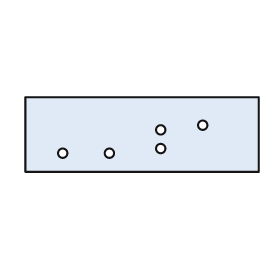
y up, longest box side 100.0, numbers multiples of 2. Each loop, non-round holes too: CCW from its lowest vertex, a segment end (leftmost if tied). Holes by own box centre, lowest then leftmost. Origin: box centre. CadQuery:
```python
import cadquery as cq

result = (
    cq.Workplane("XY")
    .moveTo(-50.0, -16.0)
    .lineTo(50.0, -16.0)
    .lineTo(50.0, 16.0)
    .lineTo(-50.0, 16.0)
    .close()
    .moveTo(-34.0, -8.0)
    .circle(2.0)
    .moveTo(-14.0, -8.0)
    .circle(2.0)
    .moveTo(8.0, -6.0)
    .circle(2.0)
    .moveTo(8.0, 2.0)
    .circle(2.0)
    .moveTo(26.0, 4.0)
    .circle(2.0)
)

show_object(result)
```